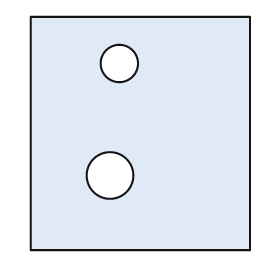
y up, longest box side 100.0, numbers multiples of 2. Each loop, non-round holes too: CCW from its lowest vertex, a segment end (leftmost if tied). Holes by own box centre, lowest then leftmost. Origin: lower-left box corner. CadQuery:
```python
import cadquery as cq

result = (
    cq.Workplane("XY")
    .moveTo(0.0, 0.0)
    .lineTo(94.0, 0.0)
    .lineTo(94.0, 100.0)
    .lineTo(0.0, 100.0)
    .close()
    .moveTo(34.0, 32.0)
    .circle(10.0)
    .moveTo(38.0, 80.0)
    .circle(8.0)
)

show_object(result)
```